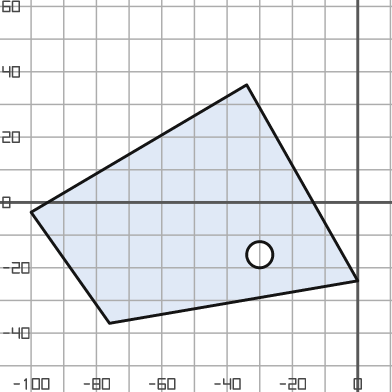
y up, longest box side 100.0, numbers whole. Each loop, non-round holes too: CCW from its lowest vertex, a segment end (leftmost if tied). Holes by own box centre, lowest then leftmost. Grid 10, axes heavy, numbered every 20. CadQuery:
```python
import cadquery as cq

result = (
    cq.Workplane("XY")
    .moveTo(-76.0, -37.0)
    .lineTo(0.0, -24.0)
    .lineTo(-34.0, 36.0)
    .lineTo(-100.0, -3.0)
    .close()
    .moveTo(-30.0, -16.0)
    .circle(4.0)
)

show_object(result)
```